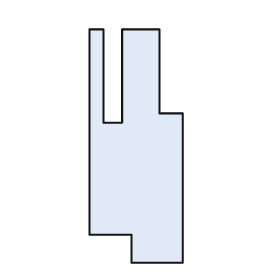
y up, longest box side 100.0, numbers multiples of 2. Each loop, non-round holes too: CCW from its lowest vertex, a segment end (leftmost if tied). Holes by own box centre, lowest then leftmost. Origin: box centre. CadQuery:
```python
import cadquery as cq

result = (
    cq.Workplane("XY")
    .moveTo(-2.0, -50.0)
    .lineTo(20.0, -50.0)
    .lineTo(20.0, 14.0)
    .lineTo(10.0, 14.0)
    .lineTo(10.0, 50.0)
    .lineTo(-6.0, 50.0)
    .lineTo(-6.0, 10.0)
    .lineTo(-14.0, 10.0)
    .lineTo(-14.0, 50.0)
    .lineTo(-20.0, 50.0)
    .lineTo(-20.0, -38.0)
    .lineTo(-2.0, -38.0)
    .close()
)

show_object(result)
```